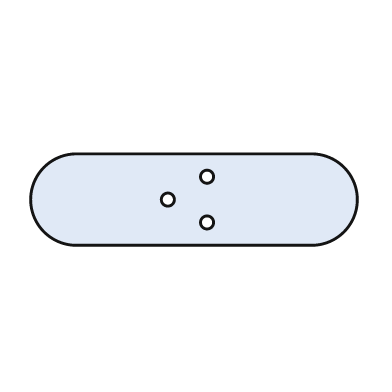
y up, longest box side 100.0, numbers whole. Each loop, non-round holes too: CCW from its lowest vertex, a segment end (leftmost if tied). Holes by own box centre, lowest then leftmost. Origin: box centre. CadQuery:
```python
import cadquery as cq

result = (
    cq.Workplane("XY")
    .moveTo(-36.0, -14.0)
    .lineTo(36.0, -14.0)
    .threePointArc((50.0, 0.0), (36.0, 14.0))
    .lineTo(-36.0, 14.0)
    .threePointArc((-50.0, 0.0), (-36.0, -14.0))
    .close()
    .moveTo(4.0, -7.0)
    .circle(2.0)
    .moveTo(-8.0, 0.0)
    .circle(2.0)
    .moveTo(4.0, 7.0)
    .circle(2.0)
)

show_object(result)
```